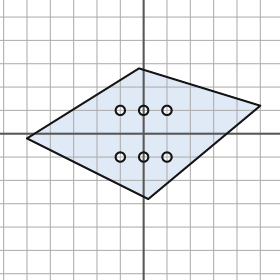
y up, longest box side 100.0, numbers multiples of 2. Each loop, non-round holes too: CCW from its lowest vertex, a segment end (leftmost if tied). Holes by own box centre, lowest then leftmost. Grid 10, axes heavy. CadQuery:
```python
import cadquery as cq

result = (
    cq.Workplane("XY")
    .moveTo(2.0, -28.0)
    .lineTo(50.0, 12.0)
    .lineTo(-2.0, 28.0)
    .lineTo(-50.0, -2.0)
    .close()
    .moveTo(-10.0, -10.0)
    .circle(2.0)
    .moveTo(0.0, -10.0)
    .circle(2.0)
    .moveTo(10.0, -10.0)
    .circle(2.0)
    .moveTo(-10.0, 10.0)
    .circle(2.0)
    .moveTo(0.0, 10.0)
    .circle(2.0)
    .moveTo(10.0, 10.0)
    .circle(2.0)
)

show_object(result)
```